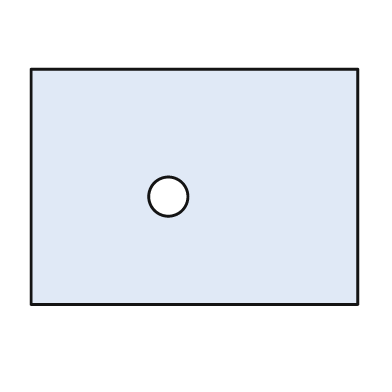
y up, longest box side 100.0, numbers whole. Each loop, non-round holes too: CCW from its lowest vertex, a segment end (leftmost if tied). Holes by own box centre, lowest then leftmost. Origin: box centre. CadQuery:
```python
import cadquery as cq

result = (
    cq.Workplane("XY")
    .moveTo(-50.0, -36.0)
    .lineTo(50.0, -36.0)
    .lineTo(50.0, 36.0)
    .lineTo(-50.0, 36.0)
    .close()
    .moveTo(-8.0, -3.0)
    .circle(6.0)
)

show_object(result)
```